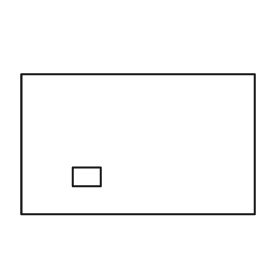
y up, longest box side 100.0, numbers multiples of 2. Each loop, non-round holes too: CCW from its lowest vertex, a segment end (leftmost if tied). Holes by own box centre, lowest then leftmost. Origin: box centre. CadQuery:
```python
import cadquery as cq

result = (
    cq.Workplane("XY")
    .moveTo(-50.0, -30.0)
    .lineTo(50.0, -30.0)
    .lineTo(50.0, 30.0)
    .lineTo(-50.0, 30.0)
    .close()
    .moveTo(-28.0, -18.0)
    .lineTo(-16.0, -18.0)
    .lineTo(-16.0, -10.0)
    .lineTo(-28.0, -10.0)
    .close()
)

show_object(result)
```